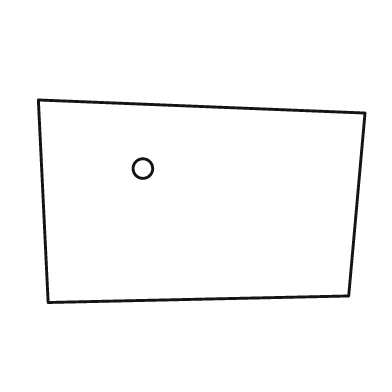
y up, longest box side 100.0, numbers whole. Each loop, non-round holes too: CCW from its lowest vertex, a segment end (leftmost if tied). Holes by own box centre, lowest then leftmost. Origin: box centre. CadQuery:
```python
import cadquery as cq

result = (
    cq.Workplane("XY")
    .moveTo(-47.0, -31.0)
    .lineTo(45.0, -29.0)
    .lineTo(50.0, 27.0)
    .lineTo(-50.0, 31.0)
    .close()
    .moveTo(-18.0, 10.0)
    .circle(3.0)
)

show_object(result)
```